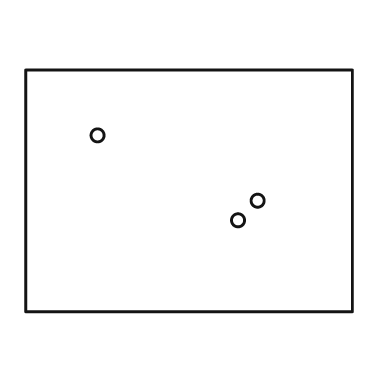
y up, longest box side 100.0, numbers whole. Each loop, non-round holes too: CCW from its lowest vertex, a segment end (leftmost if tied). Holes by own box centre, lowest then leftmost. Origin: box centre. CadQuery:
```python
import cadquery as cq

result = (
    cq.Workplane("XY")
    .moveTo(-50.0, -37.0)
    .lineTo(50.0, -37.0)
    .lineTo(50.0, 37.0)
    .lineTo(-50.0, 37.0)
    .close()
    .moveTo(15.0, -9.0)
    .circle(2.0)
    .moveTo(21.0, -3.0)
    .circle(2.0)
    .moveTo(-28.0, 17.0)
    .circle(2.0)
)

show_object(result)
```